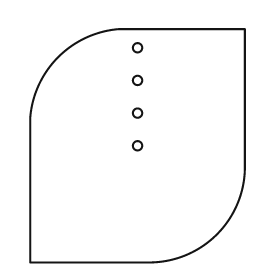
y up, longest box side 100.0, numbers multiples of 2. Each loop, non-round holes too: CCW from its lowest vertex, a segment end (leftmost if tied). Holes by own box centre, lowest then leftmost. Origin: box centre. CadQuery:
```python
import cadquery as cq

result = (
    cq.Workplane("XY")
    .moveTo(-46.0, -50.0)
    .lineTo(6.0, -50.0)
    .threePointArc((34.0, -38.0), (46.0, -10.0))
    .lineTo(46.0, 50.0)
    .lineTo(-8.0, 50.0)
    .threePointArc((-34.0, 38.0), (-46.0, 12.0))
    .close()
    .moveTo(0.0, 0.0)
    .circle(2.0)
    .moveTo(0.0, 14.0)
    .circle(2.0)
    .moveTo(0.0, 28.0)
    .circle(2.0)
    .moveTo(0.0, 42.0)
    .circle(2.0)
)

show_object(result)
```